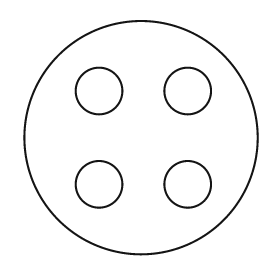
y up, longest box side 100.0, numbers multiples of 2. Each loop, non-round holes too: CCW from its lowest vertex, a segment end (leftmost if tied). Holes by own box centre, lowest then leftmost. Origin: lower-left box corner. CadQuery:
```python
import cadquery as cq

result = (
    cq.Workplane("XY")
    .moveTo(50.0, 50.0)
    .circle(50.0)
    .moveTo(32.0, 30.0)
    .circle(10.0)
    .moveTo(70.0, 30.0)
    .circle(10.0)
    .moveTo(32.0, 70.0)
    .circle(10.0)
    .moveTo(70.0, 70.0)
    .circle(10.0)
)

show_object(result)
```